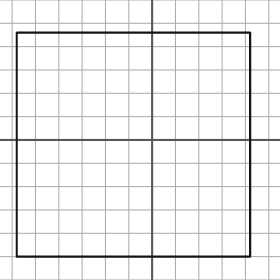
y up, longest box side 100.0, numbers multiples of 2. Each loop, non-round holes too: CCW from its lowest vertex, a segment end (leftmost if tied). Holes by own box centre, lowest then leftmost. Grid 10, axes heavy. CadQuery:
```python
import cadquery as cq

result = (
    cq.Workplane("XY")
    .moveTo(-58.0, -50.0)
    .lineTo(42.0, -50.0)
    .lineTo(42.0, 46.0)
    .lineTo(-58.0, 46.0)
    .close()
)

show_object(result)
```